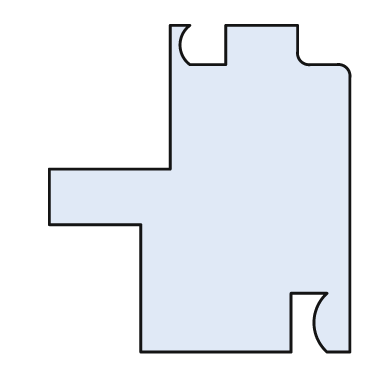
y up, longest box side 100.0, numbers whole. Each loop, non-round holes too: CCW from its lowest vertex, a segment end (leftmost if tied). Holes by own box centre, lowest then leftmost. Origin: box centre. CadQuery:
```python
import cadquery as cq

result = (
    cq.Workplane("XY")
    .moveTo(-18.0, -50.0)
    .lineTo(28.0, -50.0)
    .lineTo(28.0, -32.0)
    .lineTo(39.0, -32.0)
    .threePointArc((35.0, -41.0), (39.0, -50.0))
    .lineTo(46.0, -50.0)
    .lineTo(46.0, 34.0)
    .threePointArc((45.0, 37.0), (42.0, 38.0))
    .lineTo(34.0, 38.0)
    .threePointArc((31.0, 39.0), (30.0, 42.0))
    .lineTo(30.0, 50.0)
    .lineTo(8.0, 50.0)
    .lineTo(8.0, 38.0)
    .lineTo(-3.0, 38.0)
    .threePointArc((-6.0, 44.0), (-3.0, 50.0))
    .lineTo(-9.0, 50.0)
    .lineTo(-9.0, 6.0)
    .lineTo(-46.0, 6.0)
    .lineTo(-46.0, -11.0)
    .lineTo(-18.0, -11.0)
    .close()
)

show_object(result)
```